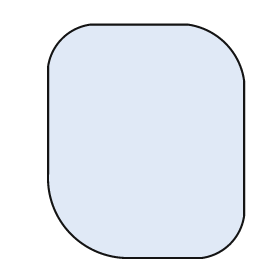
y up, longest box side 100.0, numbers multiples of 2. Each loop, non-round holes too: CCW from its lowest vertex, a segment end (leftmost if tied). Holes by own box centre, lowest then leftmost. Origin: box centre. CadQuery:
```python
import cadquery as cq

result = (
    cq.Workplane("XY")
    .moveTo(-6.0, -50.0)
    .lineTo(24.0, -50.0)
    .threePointArc((36.0, -44.0), (42.0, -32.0))
    .lineTo(42.0, 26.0)
    .threePointArc((34.0, 42.0), (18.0, 50.0))
    .lineTo(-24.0, 50.0)
    .threePointArc((-36.0, 44.0), (-42.0, 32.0))
    .lineTo(-42.0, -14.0)
    .threePointArc((-32.0, -40.0), (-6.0, -50.0))
    .close()
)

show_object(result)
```